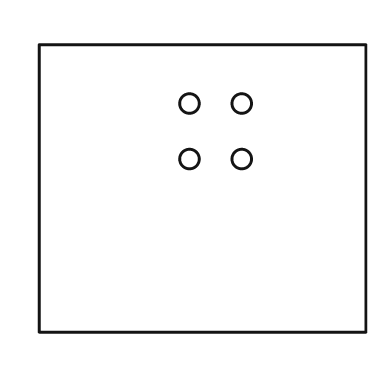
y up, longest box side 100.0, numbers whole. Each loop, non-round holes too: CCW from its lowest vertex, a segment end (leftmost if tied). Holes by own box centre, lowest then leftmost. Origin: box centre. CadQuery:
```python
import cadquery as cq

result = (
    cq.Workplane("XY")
    .moveTo(-50.0, -44.0)
    .lineTo(50.0, -44.0)
    .lineTo(50.0, 44.0)
    .lineTo(-50.0, 44.0)
    .close()
    .moveTo(-4.0, 9.0)
    .circle(3.0)
    .moveTo(12.0, 9.0)
    .circle(3.0)
    .moveTo(-4.0, 26.0)
    .circle(3.0)
    .moveTo(12.0, 26.0)
    .circle(3.0)
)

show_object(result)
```